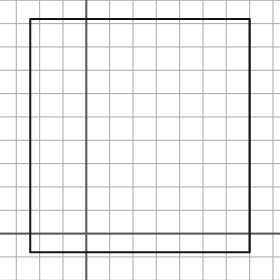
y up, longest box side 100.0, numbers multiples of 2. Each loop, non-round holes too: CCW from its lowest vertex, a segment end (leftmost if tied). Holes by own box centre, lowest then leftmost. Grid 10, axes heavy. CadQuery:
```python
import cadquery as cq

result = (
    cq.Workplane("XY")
    .moveTo(-24.0, -8.0)
    .lineTo(70.0, -8.0)
    .lineTo(70.0, 92.0)
    .lineTo(-24.0, 92.0)
    .close()
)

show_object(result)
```